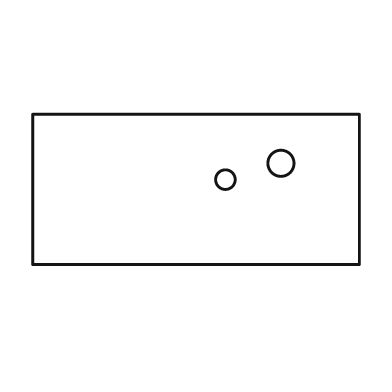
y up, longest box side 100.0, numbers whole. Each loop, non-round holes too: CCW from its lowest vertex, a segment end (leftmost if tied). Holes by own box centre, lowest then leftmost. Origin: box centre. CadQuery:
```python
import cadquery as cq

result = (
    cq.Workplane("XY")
    .moveTo(-50.0, -23.0)
    .lineTo(50.0, -23.0)
    .lineTo(50.0, 23.0)
    .lineTo(-50.0, 23.0)
    .close()
    .moveTo(9.0, 3.0)
    .circle(3.0)
    .moveTo(26.0, 8.0)
    .circle(4.0)
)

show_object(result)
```